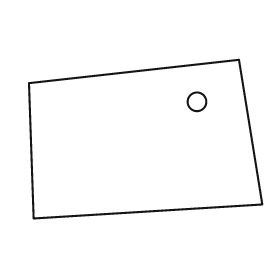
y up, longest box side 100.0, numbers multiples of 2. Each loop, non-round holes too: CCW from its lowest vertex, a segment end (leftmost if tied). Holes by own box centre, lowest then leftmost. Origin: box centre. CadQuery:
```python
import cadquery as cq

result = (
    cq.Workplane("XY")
    .moveTo(-48.0, -34.0)
    .lineTo(50.0, -28.0)
    .lineTo(40.0, 34.0)
    .lineTo(-50.0, 24.0)
    .close()
    .moveTo(22.0, 16.0)
    .circle(4.0)
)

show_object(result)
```